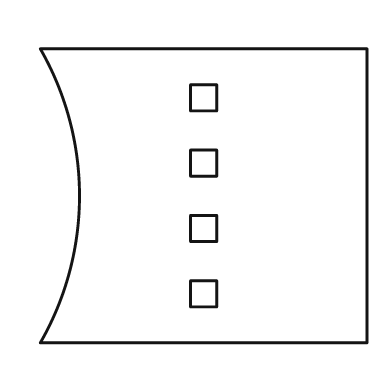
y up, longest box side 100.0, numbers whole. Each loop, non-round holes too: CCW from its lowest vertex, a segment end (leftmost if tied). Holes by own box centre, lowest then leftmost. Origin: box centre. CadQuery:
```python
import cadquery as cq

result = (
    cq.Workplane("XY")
    .moveTo(-50.0, -45.0)
    .lineTo(50.0, -45.0)
    .lineTo(50.0, 45.0)
    .lineTo(-50.0, 45.0)
    .threePointArc((-38.0, 0.0), (-50.0, -45.0))
    .close()
    .moveTo(-4.0, -34.0)
    .lineTo(4.0, -34.0)
    .lineTo(4.0, -26.0)
    .lineTo(-4.0, -26.0)
    .close()
    .moveTo(-4.0, -14.0)
    .lineTo(4.0, -14.0)
    .lineTo(4.0, -6.0)
    .lineTo(-4.0, -6.0)
    .close()
    .moveTo(-4.0, 6.0)
    .lineTo(4.0, 6.0)
    .lineTo(4.0, 14.0)
    .lineTo(-4.0, 14.0)
    .close()
    .moveTo(-4.0, 26.0)
    .lineTo(4.0, 26.0)
    .lineTo(4.0, 34.0)
    .lineTo(-4.0, 34.0)
    .close()
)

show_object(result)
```